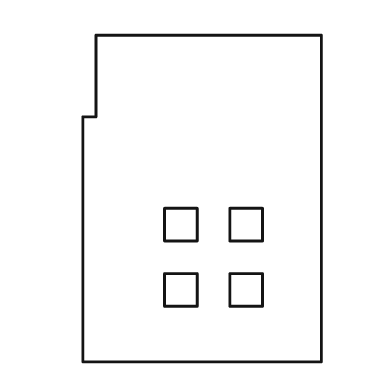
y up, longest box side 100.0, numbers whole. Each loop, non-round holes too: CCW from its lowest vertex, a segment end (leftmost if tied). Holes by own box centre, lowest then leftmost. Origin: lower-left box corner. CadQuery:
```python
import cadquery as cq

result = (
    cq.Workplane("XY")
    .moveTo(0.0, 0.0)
    .lineTo(73.0, 0.0)
    .lineTo(73.0, 100.0)
    .lineTo(4.0, 100.0)
    .lineTo(4.0, 75.0)
    .lineTo(0.0, 75.0)
    .close()
    .moveTo(25.0, 17.0)
    .lineTo(35.0, 17.0)
    .lineTo(35.0, 27.0)
    .lineTo(25.0, 27.0)
    .close()
    .moveTo(45.0, 17.0)
    .lineTo(55.0, 17.0)
    .lineTo(55.0, 27.0)
    .lineTo(45.0, 27.0)
    .close()
    .moveTo(25.0, 37.0)
    .lineTo(35.0, 37.0)
    .lineTo(35.0, 47.0)
    .lineTo(25.0, 47.0)
    .close()
    .moveTo(45.0, 37.0)
    .lineTo(55.0, 37.0)
    .lineTo(55.0, 47.0)
    .lineTo(45.0, 47.0)
    .close()
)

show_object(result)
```